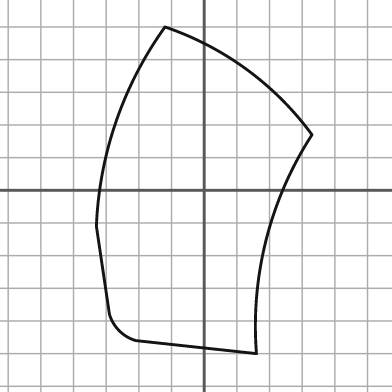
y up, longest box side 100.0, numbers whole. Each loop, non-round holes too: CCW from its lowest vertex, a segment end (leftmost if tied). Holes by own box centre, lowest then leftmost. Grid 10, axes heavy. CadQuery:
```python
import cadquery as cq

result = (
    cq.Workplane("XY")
    .moveTo(16.0, -50.0)
    .threePointArc((19.0, -15.0), (33.0, 17.0))
    .threePointArc((13.0, 37.0), (-12.0, 50.0))
    .threePointArc((-27.0, 21.0), (-33.0, -11.0))
    .lineTo(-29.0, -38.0)
    .threePointArc((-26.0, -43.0), (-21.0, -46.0))
    .close()
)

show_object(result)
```